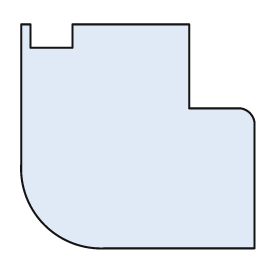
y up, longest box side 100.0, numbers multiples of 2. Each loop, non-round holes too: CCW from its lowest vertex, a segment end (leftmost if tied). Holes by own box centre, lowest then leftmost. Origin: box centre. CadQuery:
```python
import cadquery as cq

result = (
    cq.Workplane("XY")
    .moveTo(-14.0, -48.0)
    .lineTo(50.0, -48.0)
    .lineTo(50.0, 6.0)
    .threePointArc((48.0, 10.0), (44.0, 12.0))
    .lineTo(22.0, 12.0)
    .lineTo(22.0, 48.0)
    .lineTo(-28.0, 48.0)
    .lineTo(-28.0, 38.0)
    .lineTo(-46.0, 38.0)
    .lineTo(-46.0, 48.0)
    .lineTo(-50.0, 48.0)
    .lineTo(-50.0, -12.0)
    .threePointArc((-40.0, -38.0), (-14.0, -48.0))
    .close()
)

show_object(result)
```